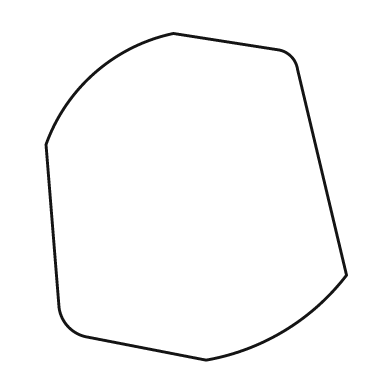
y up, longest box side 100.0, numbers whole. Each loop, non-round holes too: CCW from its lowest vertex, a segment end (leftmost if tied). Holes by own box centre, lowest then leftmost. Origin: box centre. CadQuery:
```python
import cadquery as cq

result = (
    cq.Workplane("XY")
    .moveTo(3.0, -50.0)
    .threePointArc((27.0, -41.0), (46.0, -24.0))
    .lineTo(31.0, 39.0)
    .threePointArc((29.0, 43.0), (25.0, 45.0))
    .lineTo(-7.0, 50.0)
    .threePointArc((-31.0, 38.0), (-46.0, 16.0))
    .lineTo(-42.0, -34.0)
    .threePointArc((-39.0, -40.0), (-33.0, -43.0))
    .close()
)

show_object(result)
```